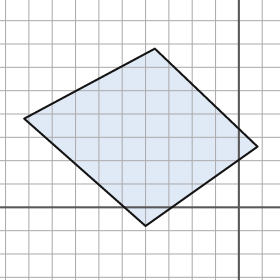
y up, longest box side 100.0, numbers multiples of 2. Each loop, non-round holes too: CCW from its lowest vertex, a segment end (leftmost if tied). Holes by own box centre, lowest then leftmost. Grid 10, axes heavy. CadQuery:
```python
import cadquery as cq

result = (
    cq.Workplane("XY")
    .moveTo(-40.0, -8.0)
    .lineTo(8.0, 26.0)
    .lineTo(-36.0, 68.0)
    .lineTo(-92.0, 38.0)
    .close()
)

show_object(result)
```